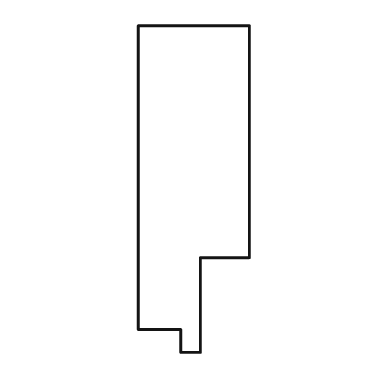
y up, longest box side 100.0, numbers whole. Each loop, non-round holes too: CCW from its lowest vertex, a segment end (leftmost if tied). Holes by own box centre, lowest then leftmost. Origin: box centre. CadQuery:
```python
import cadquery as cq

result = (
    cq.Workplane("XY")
    .moveTo(-4.0, -50.0)
    .lineTo(2.0, -50.0)
    .lineTo(2.0, -21.0)
    .lineTo(17.0, -21.0)
    .lineTo(17.0, 50.0)
    .lineTo(-17.0, 50.0)
    .lineTo(-17.0, -43.0)
    .lineTo(-4.0, -43.0)
    .close()
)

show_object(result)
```